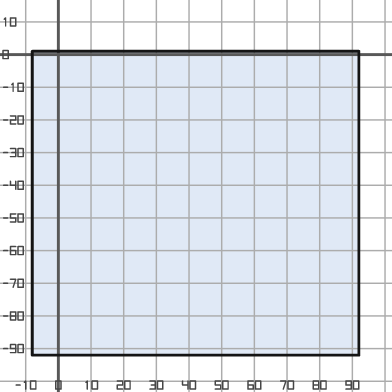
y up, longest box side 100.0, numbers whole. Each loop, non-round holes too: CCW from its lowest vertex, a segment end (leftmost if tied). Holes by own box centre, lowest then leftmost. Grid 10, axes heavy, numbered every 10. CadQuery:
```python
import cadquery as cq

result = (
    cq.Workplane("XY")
    .moveTo(-8.0, -92.0)
    .lineTo(92.0, -92.0)
    .lineTo(92.0, 1.0)
    .lineTo(-8.0, 1.0)
    .close()
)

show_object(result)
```